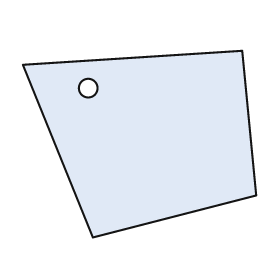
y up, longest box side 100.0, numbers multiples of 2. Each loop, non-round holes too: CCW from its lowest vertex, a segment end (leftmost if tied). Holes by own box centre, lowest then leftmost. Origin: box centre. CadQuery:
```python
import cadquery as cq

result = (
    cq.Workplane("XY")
    .moveTo(-20.0, -40.0)
    .lineTo(50.0, -22.0)
    .lineTo(44.0, 40.0)
    .lineTo(-50.0, 34.0)
    .close()
    .moveTo(-22.0, 24.0)
    .circle(4.0)
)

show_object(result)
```